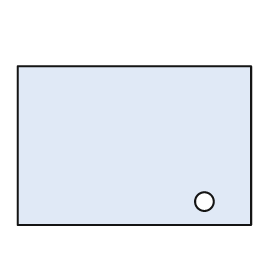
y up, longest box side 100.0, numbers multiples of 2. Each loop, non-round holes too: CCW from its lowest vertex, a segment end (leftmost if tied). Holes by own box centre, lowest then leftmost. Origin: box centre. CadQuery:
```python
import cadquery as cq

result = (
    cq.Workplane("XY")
    .moveTo(-50.0, -34.0)
    .lineTo(50.0, -34.0)
    .lineTo(50.0, 34.0)
    .lineTo(-50.0, 34.0)
    .close()
    .moveTo(30.0, -24.0)
    .circle(4.0)
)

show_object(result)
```